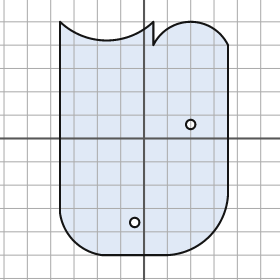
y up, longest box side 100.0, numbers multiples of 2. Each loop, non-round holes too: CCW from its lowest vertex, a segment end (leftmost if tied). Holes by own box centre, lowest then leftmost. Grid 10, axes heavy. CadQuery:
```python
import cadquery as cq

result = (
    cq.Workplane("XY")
    .moveTo(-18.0, -50.0)
    .lineTo(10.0, -50.0)
    .threePointArc((28.0, -42.0), (36.0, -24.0))
    .lineTo(36.0, 40.0)
    .threePointArc((20.0, 50.0), (4.0, 40.0))
    .lineTo(4.0, 50.0)
    .threePointArc((-16.0, 42.0), (-36.0, 50.0))
    .lineTo(-36.0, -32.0)
    .threePointArc((-30.0, -44.0), (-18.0, -50.0))
    .close()
    .moveTo(-4.0, -36.0)
    .circle(2.0)
    .moveTo(20.0, 6.0)
    .circle(2.0)
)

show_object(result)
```